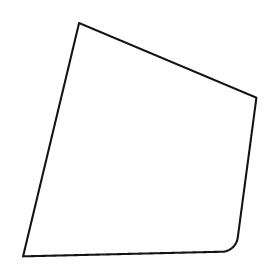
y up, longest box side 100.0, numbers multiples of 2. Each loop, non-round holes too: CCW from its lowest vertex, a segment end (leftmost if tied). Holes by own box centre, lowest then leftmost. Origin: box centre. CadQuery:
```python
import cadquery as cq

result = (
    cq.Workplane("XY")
    .moveTo(-50.0, -50.0)
    .lineTo(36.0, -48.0)
    .threePointArc((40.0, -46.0), (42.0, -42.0))
    .lineTo(50.0, 18.0)
    .lineTo(-26.0, 50.0)
    .close()
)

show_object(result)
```